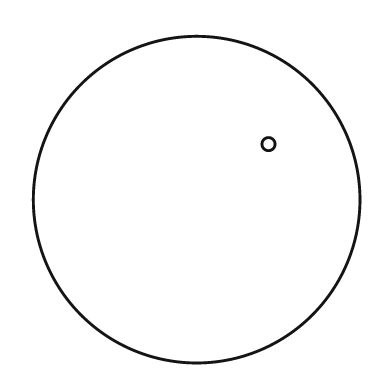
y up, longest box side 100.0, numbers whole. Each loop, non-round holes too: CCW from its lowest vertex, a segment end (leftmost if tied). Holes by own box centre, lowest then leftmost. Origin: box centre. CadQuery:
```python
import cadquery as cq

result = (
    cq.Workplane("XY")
    .moveTo(0.0, 0.0)
    .circle(50.0)
    .moveTo(22.0, 17.0)
    .circle(2.0)
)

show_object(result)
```